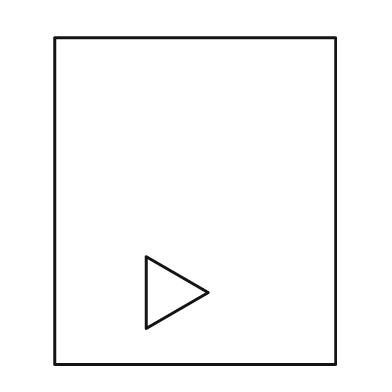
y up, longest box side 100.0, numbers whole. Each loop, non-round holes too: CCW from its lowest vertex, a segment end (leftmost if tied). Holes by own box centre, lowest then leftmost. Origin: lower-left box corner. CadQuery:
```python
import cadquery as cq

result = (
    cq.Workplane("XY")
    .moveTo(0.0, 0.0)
    .lineTo(86.0, 0.0)
    .lineTo(86.0, 100.0)
    .lineTo(0.0, 100.0)
    .close()
    .moveTo(28.0, 11.0)
    .lineTo(47.0, 22.0)
    .lineTo(28.0, 33.0)
    .close()
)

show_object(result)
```